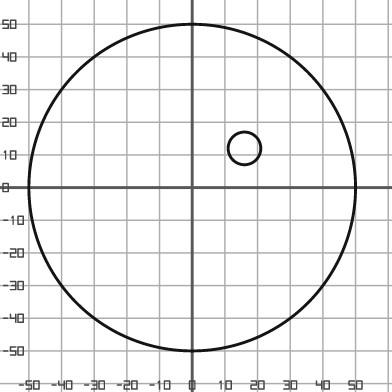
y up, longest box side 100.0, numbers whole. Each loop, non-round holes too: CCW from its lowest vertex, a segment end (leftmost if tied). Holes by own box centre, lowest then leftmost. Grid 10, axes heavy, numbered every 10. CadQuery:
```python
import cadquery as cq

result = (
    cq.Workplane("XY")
    .moveTo(0.0, 0.0)
    .circle(50.0)
    .moveTo(16.0, 12.0)
    .circle(5.0)
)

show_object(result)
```